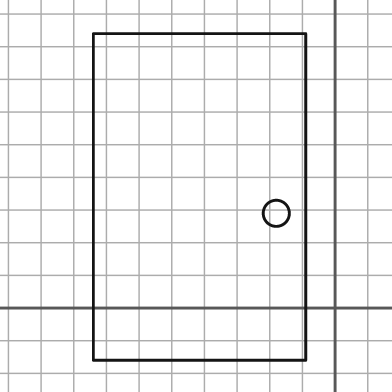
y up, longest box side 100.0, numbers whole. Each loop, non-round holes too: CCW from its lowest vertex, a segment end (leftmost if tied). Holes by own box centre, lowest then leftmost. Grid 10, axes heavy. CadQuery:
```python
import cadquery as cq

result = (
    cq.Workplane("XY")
    .moveTo(-74.0, -16.0)
    .lineTo(-9.0, -16.0)
    .lineTo(-9.0, 84.0)
    .lineTo(-74.0, 84.0)
    .close()
    .moveTo(-18.0, 29.0)
    .circle(4.0)
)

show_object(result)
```